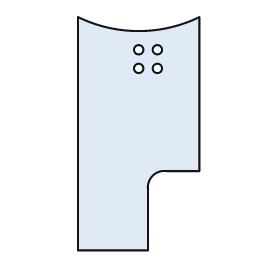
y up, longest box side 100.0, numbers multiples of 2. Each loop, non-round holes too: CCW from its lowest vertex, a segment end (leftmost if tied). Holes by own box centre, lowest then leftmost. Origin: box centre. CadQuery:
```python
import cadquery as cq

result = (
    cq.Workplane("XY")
    .moveTo(-26.0, -50.0)
    .lineTo(4.0, -50.0)
    .lineTo(4.0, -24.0)
    .threePointArc((6.0, -18.0), (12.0, -16.0))
    .lineTo(26.0, -16.0)
    .lineTo(26.0, 50.0)
    .threePointArc((0.0, 44.0), (-26.0, 50.0))
    .close()
    .moveTo(0.0, 28.0)
    .circle(2.0)
    .moveTo(8.0, 28.0)
    .circle(2.0)
    .moveTo(0.0, 36.0)
    .circle(2.0)
    .moveTo(8.0, 36.0)
    .circle(2.0)
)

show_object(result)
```